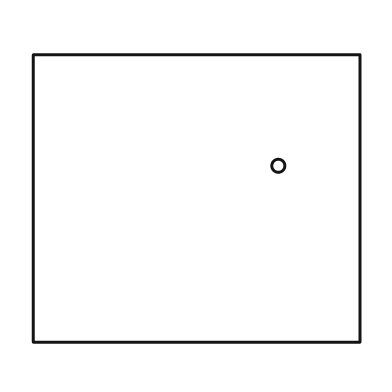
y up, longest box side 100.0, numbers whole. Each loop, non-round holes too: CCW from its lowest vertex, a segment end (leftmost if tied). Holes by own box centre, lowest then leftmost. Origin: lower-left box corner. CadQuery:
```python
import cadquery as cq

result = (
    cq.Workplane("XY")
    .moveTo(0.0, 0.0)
    .lineTo(100.0, 0.0)
    .lineTo(100.0, 88.0)
    .lineTo(0.0, 88.0)
    .close()
    .moveTo(75.0, 54.0)
    .circle(2.0)
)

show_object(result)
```